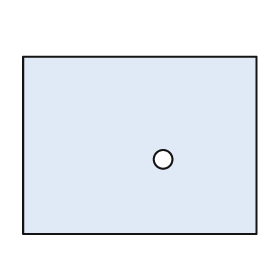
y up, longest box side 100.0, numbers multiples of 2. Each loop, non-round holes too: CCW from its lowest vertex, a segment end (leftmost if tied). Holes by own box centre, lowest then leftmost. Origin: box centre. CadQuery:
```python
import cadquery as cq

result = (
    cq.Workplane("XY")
    .moveTo(-50.0, -38.0)
    .lineTo(50.0, -38.0)
    .lineTo(50.0, 38.0)
    .lineTo(-50.0, 38.0)
    .close()
    .moveTo(10.0, -6.0)
    .circle(4.0)
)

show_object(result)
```